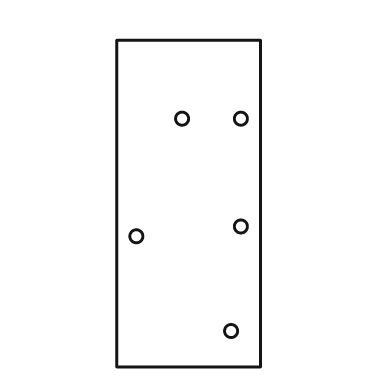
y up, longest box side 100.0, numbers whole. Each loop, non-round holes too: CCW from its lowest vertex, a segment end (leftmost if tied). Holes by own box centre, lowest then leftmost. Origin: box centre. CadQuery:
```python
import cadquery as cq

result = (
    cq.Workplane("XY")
    .moveTo(-22.0, -50.0)
    .lineTo(22.0, -50.0)
    .lineTo(22.0, 50.0)
    .lineTo(-22.0, 50.0)
    .close()
    .moveTo(13.0, -39.0)
    .circle(2.0)
    .moveTo(-16.0, -10.0)
    .circle(2.0)
    .moveTo(16.0, -7.0)
    .circle(2.0)
    .moveTo(-2.0, 26.0)
    .circle(2.0)
    .moveTo(16.0, 26.0)
    .circle(2.0)
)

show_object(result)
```